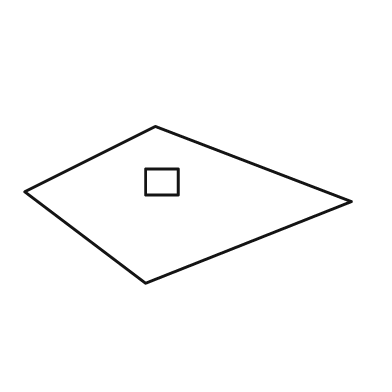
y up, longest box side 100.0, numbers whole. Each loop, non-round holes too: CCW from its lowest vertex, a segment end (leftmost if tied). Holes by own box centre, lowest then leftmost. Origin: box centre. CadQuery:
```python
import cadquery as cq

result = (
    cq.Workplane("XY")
    .moveTo(-13.0, -24.0)
    .lineTo(50.0, 1.0)
    .lineTo(-10.0, 24.0)
    .lineTo(-50.0, 4.0)
    .close()
    .moveTo(-13.0, 3.0)
    .lineTo(-3.0, 3.0)
    .lineTo(-3.0, 11.0)
    .lineTo(-13.0, 11.0)
    .close()
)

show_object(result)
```